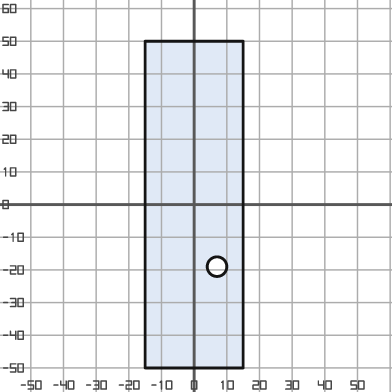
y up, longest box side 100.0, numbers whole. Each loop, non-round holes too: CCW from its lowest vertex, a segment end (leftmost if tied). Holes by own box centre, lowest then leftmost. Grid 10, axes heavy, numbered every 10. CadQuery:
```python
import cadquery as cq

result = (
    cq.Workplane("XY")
    .moveTo(-15.0, -50.0)
    .lineTo(15.0, -50.0)
    .lineTo(15.0, 50.0)
    .lineTo(-15.0, 50.0)
    .close()
    .moveTo(7.0, -19.0)
    .circle(3.0)
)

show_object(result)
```